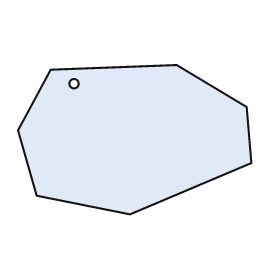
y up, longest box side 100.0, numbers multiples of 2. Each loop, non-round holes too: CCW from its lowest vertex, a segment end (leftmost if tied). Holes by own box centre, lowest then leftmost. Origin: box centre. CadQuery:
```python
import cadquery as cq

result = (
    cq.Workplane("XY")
    .moveTo(-2.0, -32.0)
    .lineTo(50.0, -10.0)
    .lineTo(48.0, 14.0)
    .lineTo(18.0, 32.0)
    .lineTo(-36.0, 30.0)
    .lineTo(-50.0, 4.0)
    .lineTo(-42.0, -24.0)
    .close()
    .moveTo(-26.0, 24.0)
    .circle(2.0)
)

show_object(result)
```